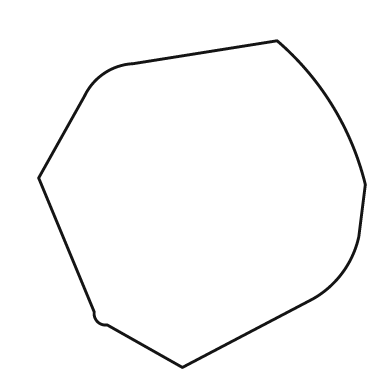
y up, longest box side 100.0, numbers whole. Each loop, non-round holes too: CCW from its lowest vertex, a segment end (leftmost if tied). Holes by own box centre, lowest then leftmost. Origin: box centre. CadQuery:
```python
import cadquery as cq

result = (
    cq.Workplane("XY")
    .moveTo(-6.0, -50.0)
    .lineTo(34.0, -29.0)
    .threePointArc((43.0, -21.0), (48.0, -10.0))
    .lineTo(50.0, 6.0)
    .threePointArc((40.0, 30.0), (23.0, 50.0))
    .lineTo(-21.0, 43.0)
    .threePointArc((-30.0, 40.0), (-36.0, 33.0))
    .lineTo(-50.0, 8.0)
    .lineTo(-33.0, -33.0)
    .threePointArc((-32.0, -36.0), (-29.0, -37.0))
    .close()
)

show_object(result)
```